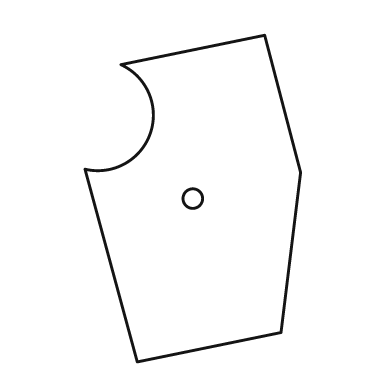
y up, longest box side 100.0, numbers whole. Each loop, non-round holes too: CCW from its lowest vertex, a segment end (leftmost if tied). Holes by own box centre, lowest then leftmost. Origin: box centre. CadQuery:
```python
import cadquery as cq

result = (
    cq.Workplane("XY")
    .moveTo(-17.0, -50.0)
    .lineTo(27.0, -41.0)
    .lineTo(33.0, 8.0)
    .lineTo(22.0, 50.0)
    .lineTo(-22.0, 41.0)
    .threePointArc((-13.0, 20.0), (-33.0, 9.0))
    .close()
    .moveTo(0.0, 0.0)
    .circle(3.0)
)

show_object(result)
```